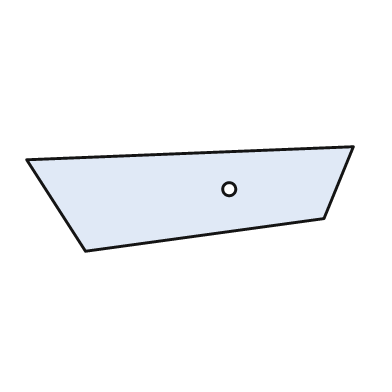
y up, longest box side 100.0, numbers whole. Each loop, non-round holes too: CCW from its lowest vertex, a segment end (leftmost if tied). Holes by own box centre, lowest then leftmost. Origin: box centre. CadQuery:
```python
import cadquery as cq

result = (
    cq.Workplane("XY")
    .moveTo(-32.0, -16.0)
    .lineTo(41.0, -6.0)
    .lineTo(50.0, 16.0)
    .lineTo(-50.0, 12.0)
    .close()
    .moveTo(12.0, 3.0)
    .circle(2.0)
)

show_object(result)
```